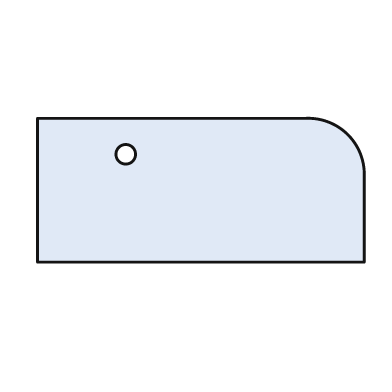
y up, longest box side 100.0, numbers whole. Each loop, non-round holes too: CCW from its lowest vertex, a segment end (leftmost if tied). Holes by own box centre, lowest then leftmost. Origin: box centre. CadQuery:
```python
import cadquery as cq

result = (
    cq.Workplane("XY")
    .moveTo(-50.0, -22.0)
    .lineTo(50.0, -22.0)
    .lineTo(50.0, 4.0)
    .threePointArc((45.0, 17.0), (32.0, 22.0))
    .lineTo(-50.0, 22.0)
    .close()
    .moveTo(-23.0, 11.0)
    .circle(3.0)
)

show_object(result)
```